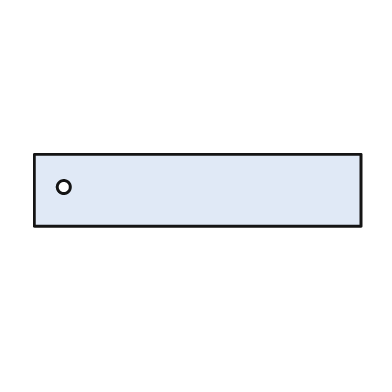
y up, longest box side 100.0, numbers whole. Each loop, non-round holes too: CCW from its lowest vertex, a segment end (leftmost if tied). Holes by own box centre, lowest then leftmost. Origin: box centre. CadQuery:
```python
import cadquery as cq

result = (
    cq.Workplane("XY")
    .moveTo(-50.0, -11.0)
    .lineTo(50.0, -11.0)
    .lineTo(50.0, 11.0)
    .lineTo(-50.0, 11.0)
    .close()
    .moveTo(-41.0, 1.0)
    .circle(2.0)
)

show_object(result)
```